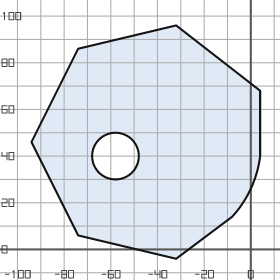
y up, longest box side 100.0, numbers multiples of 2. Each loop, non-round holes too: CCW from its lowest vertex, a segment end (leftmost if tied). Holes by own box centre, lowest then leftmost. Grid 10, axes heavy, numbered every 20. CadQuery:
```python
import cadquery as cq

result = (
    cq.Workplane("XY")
    .moveTo(-32.0, -4.0)
    .lineTo(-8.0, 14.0)
    .threePointArc((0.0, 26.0), (4.0, 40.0))
    .lineTo(4.0, 68.0)
    .lineTo(-32.0, 96.0)
    .lineTo(-74.0, 86.0)
    .lineTo(-94.0, 46.0)
    .lineTo(-74.0, 6.0)
    .close()
    .moveTo(-58.0, 40.0)
    .circle(10.0)
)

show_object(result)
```